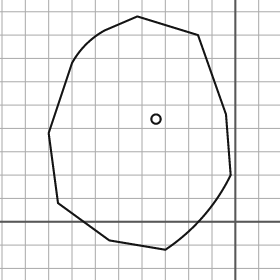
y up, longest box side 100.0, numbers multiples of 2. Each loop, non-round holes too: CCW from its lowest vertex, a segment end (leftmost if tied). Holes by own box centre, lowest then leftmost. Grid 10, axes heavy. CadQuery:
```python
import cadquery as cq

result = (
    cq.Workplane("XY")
    .moveTo(-30.0, -12.0)
    .threePointArc((-14.0, 2.0), (-2.0, 20.0))
    .lineTo(-4.0, 46.0)
    .lineTo(-16.0, 80.0)
    .lineTo(-42.0, 88.0)
    .lineTo(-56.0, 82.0)
    .threePointArc((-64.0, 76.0), (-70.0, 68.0))
    .lineTo(-80.0, 38.0)
    .lineTo(-76.0, 8.0)
    .lineTo(-54.0, -8.0)
    .close()
    .moveTo(-34.0, 44.0)
    .circle(2.0)
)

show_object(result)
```